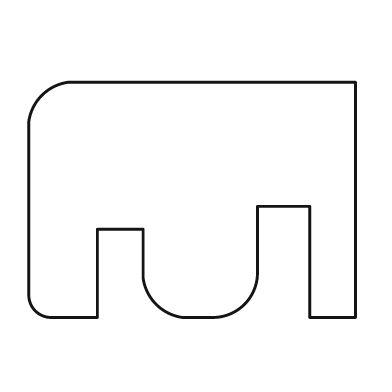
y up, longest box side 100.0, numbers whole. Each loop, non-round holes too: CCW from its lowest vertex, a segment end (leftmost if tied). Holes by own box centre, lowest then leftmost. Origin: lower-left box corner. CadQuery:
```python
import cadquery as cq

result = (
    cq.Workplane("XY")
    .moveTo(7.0, 0.0)
    .lineTo(21.0, 0.0)
    .lineTo(21.0, 27.0)
    .lineTo(35.0, 27.0)
    .lineTo(35.0, 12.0)
    .threePointArc((39.0, 4.0), (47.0, 0.0))
    .lineTo(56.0, 0.0)
    .threePointArc((66.0, 4.0), (70.0, 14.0))
    .lineTo(70.0, 34.0)
    .lineTo(86.0, 34.0)
    .lineTo(86.0, 0.0)
    .lineTo(100.0, 0.0)
    .lineTo(100.0, 72.0)
    .lineTo(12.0, 72.0)
    .threePointArc((4.0, 68.0), (0.0, 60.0))
    .lineTo(0.0, 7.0)
    .threePointArc((2.0, 2.0), (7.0, 0.0))
    .close()
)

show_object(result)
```